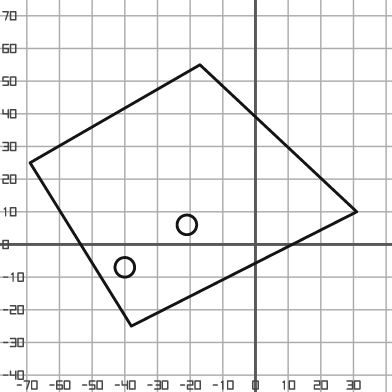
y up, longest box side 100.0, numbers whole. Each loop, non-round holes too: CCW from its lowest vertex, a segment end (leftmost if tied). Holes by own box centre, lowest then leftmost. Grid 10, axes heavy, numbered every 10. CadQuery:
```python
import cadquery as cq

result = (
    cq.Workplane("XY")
    .moveTo(-38.0, -25.0)
    .lineTo(31.0, 10.0)
    .lineTo(-17.0, 55.0)
    .lineTo(-69.0, 25.0)
    .close()
    .moveTo(-40.0, -7.0)
    .circle(3.0)
    .moveTo(-21.0, 6.0)
    .circle(3.0)
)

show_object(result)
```